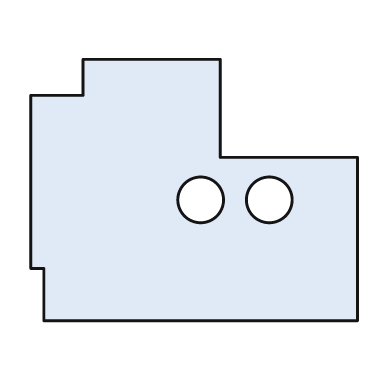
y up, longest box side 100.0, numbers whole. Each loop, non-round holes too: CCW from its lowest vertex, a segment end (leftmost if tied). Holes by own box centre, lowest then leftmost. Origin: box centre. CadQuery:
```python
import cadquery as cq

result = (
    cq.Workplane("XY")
    .moveTo(-46.0, -40.0)
    .lineTo(50.0, -40.0)
    .lineTo(50.0, 10.0)
    .lineTo(8.0, 10.0)
    .lineTo(8.0, 40.0)
    .lineTo(-34.0, 40.0)
    .lineTo(-34.0, 29.0)
    .lineTo(-50.0, 29.0)
    .lineTo(-50.0, -24.0)
    .lineTo(-46.0, -24.0)
    .close()
    .moveTo(2.0, -3.0)
    .circle(7.0)
    .moveTo(23.0, -3.0)
    .circle(7.0)
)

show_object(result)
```